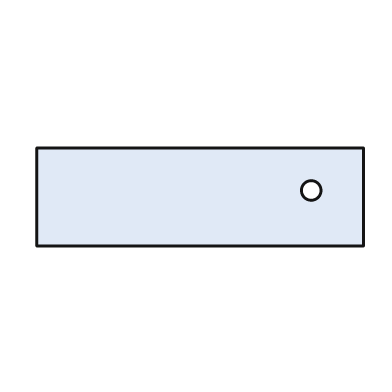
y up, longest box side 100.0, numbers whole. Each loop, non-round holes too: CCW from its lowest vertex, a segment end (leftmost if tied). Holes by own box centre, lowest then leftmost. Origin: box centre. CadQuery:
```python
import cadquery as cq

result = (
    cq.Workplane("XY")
    .moveTo(-50.0, -15.0)
    .lineTo(50.0, -15.0)
    .lineTo(50.0, 15.0)
    .lineTo(-50.0, 15.0)
    .close()
    .moveTo(34.0, 2.0)
    .circle(3.0)
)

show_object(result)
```